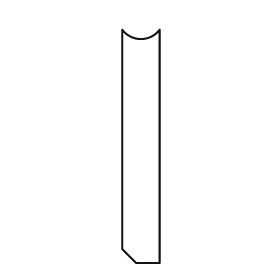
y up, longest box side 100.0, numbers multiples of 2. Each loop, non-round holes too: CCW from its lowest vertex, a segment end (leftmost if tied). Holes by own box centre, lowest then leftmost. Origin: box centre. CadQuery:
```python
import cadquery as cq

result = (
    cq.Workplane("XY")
    .moveTo(-2.0, -50.0)
    .lineTo(8.0, -50.0)
    .lineTo(8.0, 50.0)
    .threePointArc((0.0, 46.0), (-8.0, 50.0))
    .lineTo(-8.0, -44.0)
    .close()
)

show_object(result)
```